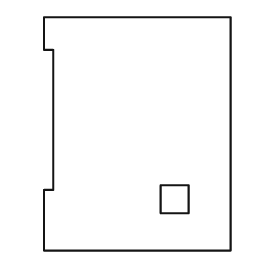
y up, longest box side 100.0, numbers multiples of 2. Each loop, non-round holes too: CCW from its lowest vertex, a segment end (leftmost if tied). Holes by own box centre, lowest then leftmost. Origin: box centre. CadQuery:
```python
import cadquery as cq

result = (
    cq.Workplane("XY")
    .moveTo(-40.0, -50.0)
    .lineTo(40.0, -50.0)
    .lineTo(40.0, 50.0)
    .lineTo(-40.0, 50.0)
    .lineTo(-40.0, 36.0)
    .lineTo(-36.0, 36.0)
    .lineTo(-36.0, -24.0)
    .lineTo(-40.0, -24.0)
    .close()
    .moveTo(10.0, -34.0)
    .lineTo(22.0, -34.0)
    .lineTo(22.0, -22.0)
    .lineTo(10.0, -22.0)
    .close()
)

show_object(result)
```